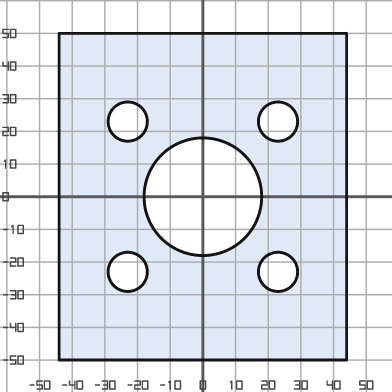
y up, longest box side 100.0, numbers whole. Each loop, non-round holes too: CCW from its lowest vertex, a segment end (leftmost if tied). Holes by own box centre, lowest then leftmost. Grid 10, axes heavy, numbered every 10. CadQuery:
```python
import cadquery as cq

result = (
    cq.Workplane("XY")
    .moveTo(-44.0, -50.0)
    .lineTo(44.0, -50.0)
    .lineTo(44.0, 50.0)
    .lineTo(-44.0, 50.0)
    .close()
    .moveTo(-23.0, -23.0)
    .circle(6.0)
    .moveTo(23.0, -23.0)
    .circle(6.0)
    .moveTo(0.0, 0.0)
    .circle(18.0)
    .moveTo(-23.0, 23.0)
    .circle(6.0)
    .moveTo(23.0, 23.0)
    .circle(6.0)
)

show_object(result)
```